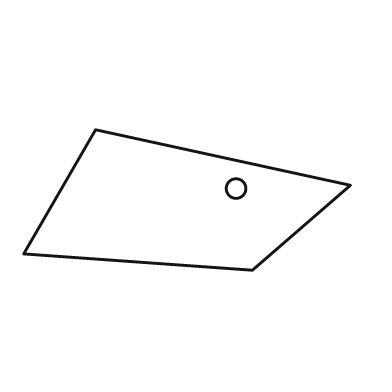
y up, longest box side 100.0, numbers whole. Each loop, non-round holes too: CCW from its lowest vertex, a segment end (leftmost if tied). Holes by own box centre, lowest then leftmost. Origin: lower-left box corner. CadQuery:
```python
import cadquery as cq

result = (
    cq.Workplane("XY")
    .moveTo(70.0, 0.0)
    .lineTo(100.0, 26.0)
    .lineTo(22.0, 43.0)
    .lineTo(0.0, 5.0)
    .close()
    .moveTo(65.0, 25.0)
    .circle(3.0)
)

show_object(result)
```